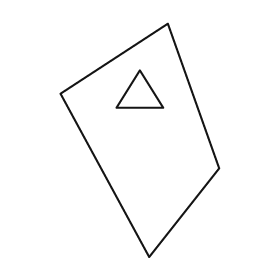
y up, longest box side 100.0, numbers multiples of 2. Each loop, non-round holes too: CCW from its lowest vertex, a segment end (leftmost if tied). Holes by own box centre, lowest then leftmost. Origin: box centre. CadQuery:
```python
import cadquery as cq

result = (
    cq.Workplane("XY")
    .moveTo(4.0, -50.0)
    .lineTo(34.0, -12.0)
    .lineTo(12.0, 50.0)
    .lineTo(-34.0, 20.0)
    .close()
    .moveTo(-10.0, 14.0)
    .lineTo(10.0, 14.0)
    .lineTo(0.0, 30.0)
    .close()
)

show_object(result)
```